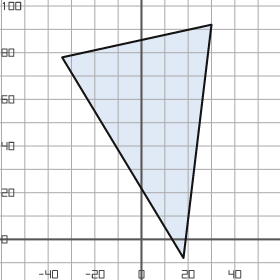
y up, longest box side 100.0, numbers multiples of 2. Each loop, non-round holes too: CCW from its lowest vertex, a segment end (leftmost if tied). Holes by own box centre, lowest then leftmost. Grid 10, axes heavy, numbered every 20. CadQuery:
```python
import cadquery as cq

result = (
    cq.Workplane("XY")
    .moveTo(18.0, -8.0)
    .lineTo(30.0, 92.0)
    .lineTo(-34.0, 78.0)
    .close()
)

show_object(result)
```